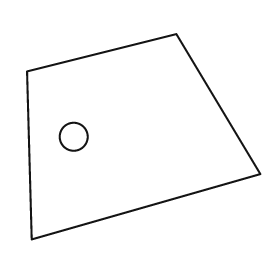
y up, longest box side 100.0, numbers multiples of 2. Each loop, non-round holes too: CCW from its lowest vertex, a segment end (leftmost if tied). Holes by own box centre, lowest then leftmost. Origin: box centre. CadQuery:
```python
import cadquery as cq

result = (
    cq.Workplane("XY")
    .moveTo(-48.0, -44.0)
    .lineTo(50.0, -16.0)
    .lineTo(14.0, 44.0)
    .lineTo(-50.0, 28.0)
    .close()
    .moveTo(-30.0, 0.0)
    .circle(6.0)
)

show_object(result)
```